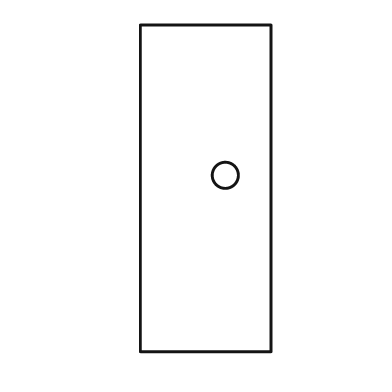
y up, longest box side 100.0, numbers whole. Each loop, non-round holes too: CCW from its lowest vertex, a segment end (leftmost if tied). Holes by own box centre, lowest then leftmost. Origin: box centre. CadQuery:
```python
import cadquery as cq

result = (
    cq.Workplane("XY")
    .moveTo(-20.0, -50.0)
    .lineTo(20.0, -50.0)
    .lineTo(20.0, 50.0)
    .lineTo(-20.0, 50.0)
    .close()
    .moveTo(6.0, 4.0)
    .circle(4.0)
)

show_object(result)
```